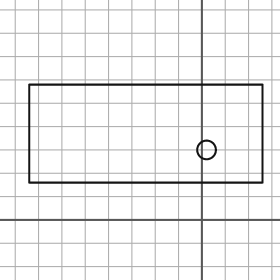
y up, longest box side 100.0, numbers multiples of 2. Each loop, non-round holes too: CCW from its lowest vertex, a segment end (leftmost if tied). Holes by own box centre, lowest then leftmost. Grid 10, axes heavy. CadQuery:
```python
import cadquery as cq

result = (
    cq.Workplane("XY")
    .moveTo(-74.0, 16.0)
    .lineTo(26.0, 16.0)
    .lineTo(26.0, 58.0)
    .lineTo(-74.0, 58.0)
    .close()
    .moveTo(2.0, 30.0)
    .circle(4.0)
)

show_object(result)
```